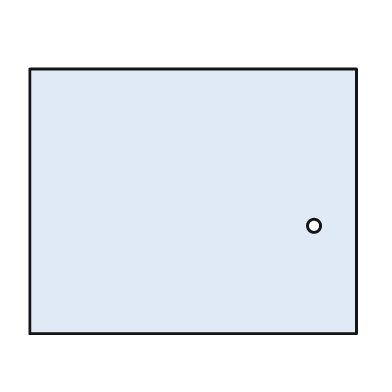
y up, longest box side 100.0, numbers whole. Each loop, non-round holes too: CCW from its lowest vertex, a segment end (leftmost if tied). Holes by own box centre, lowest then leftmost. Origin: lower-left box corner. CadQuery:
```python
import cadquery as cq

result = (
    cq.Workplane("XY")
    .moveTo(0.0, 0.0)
    .lineTo(100.0, 0.0)
    .lineTo(100.0, 81.0)
    .lineTo(0.0, 81.0)
    .close()
    .moveTo(87.0, 33.0)
    .circle(2.0)
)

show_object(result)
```